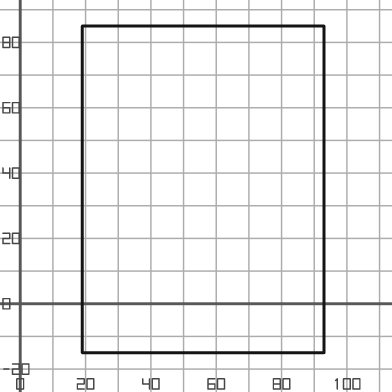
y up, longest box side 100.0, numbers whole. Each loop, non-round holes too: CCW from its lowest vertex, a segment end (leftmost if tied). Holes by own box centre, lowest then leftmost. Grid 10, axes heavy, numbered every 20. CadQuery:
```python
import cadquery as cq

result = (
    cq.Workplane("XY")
    .moveTo(19.0, -15.0)
    .lineTo(93.0, -15.0)
    .lineTo(93.0, 85.0)
    .lineTo(19.0, 85.0)
    .close()
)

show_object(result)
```